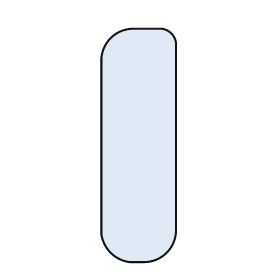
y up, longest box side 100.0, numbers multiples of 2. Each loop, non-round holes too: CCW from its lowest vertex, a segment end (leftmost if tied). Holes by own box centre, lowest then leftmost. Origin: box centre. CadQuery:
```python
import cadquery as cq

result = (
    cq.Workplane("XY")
    .moveTo(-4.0, -50.0)
    .lineTo(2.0, -50.0)
    .threePointArc((12.0, -46.0), (16.0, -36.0))
    .lineTo(16.0, 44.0)
    .threePointArc((14.0, 48.0), (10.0, 50.0))
    .lineTo(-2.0, 50.0)
    .threePointArc((-12.0, 46.0), (-16.0, 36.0))
    .lineTo(-16.0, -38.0)
    .threePointArc((-12.0, -46.0), (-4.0, -50.0))
    .close()
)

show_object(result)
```